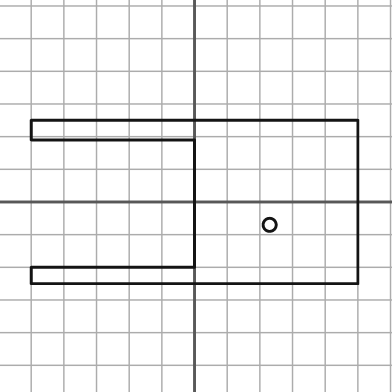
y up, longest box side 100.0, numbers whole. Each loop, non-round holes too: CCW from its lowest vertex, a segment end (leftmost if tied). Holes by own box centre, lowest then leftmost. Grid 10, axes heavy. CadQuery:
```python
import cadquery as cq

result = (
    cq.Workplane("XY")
    .moveTo(-50.0, -25.0)
    .lineTo(50.0, -25.0)
    .lineTo(50.0, 25.0)
    .lineTo(-50.0, 25.0)
    .lineTo(-50.0, 19.0)
    .lineTo(0.0, 19.0)
    .lineTo(0.0, -20.0)
    .lineTo(-50.0, -20.0)
    .close()
    .moveTo(23.0, -7.0)
    .circle(2.0)
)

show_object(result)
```